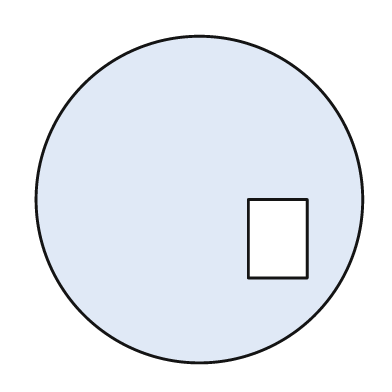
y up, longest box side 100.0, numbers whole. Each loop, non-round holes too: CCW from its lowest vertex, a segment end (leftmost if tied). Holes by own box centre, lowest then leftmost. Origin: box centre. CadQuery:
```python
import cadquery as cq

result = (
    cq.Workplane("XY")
    .moveTo(0.0, 0.0)
    .circle(50.0)
    .moveTo(15.0, -24.0)
    .lineTo(33.0, -24.0)
    .lineTo(33.0, 0.0)
    .lineTo(15.0, 0.0)
    .close()
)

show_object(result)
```